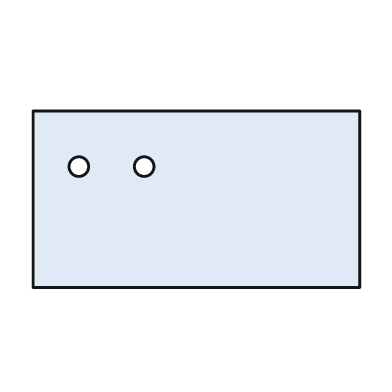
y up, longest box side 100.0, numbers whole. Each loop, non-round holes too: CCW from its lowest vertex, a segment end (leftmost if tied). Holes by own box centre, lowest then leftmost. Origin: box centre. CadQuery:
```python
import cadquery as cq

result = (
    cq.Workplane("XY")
    .moveTo(-50.0, -27.0)
    .lineTo(50.0, -27.0)
    .lineTo(50.0, 27.0)
    .lineTo(-50.0, 27.0)
    .close()
    .moveTo(-36.0, 10.0)
    .circle(3.0)
    .moveTo(-16.0, 10.0)
    .circle(3.0)
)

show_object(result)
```